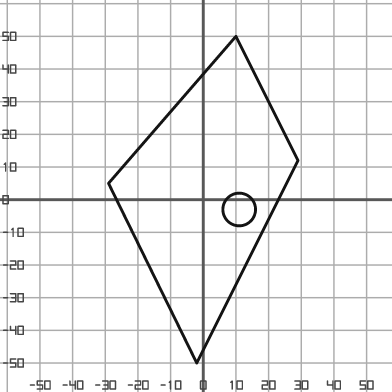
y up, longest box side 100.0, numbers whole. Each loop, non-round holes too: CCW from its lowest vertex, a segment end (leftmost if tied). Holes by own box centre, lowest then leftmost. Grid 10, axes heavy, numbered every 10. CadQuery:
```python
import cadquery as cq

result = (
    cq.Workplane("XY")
    .moveTo(-2.0, -50.0)
    .lineTo(29.0, 12.0)
    .lineTo(10.0, 50.0)
    .lineTo(-29.0, 5.0)
    .close()
    .moveTo(11.0, -3.0)
    .circle(5.0)
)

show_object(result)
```